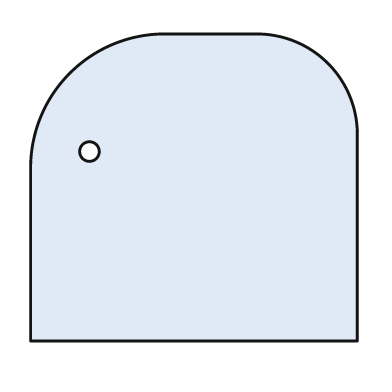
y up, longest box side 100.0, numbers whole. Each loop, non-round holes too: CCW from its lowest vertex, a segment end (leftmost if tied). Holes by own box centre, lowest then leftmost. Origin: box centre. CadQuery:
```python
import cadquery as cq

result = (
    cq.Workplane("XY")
    .moveTo(-50.0, -47.0)
    .lineTo(50.0, -47.0)
    .lineTo(50.0, 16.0)
    .threePointArc((41.0, 38.0), (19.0, 47.0))
    .lineTo(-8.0, 47.0)
    .threePointArc((-38.0, 35.0), (-50.0, 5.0))
    .close()
    .moveTo(-32.0, 11.0)
    .circle(3.0)
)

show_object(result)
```